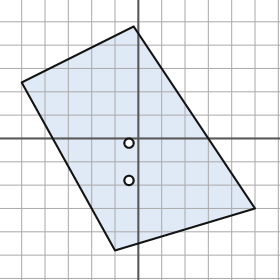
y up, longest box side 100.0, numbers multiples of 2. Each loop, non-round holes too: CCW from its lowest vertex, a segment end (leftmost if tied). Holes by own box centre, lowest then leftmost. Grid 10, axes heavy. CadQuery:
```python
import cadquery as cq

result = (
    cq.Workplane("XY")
    .moveTo(-10.0, -48.0)
    .lineTo(50.0, -30.0)
    .lineTo(-2.0, 48.0)
    .lineTo(-50.0, 24.0)
    .close()
    .moveTo(-4.0, -18.0)
    .circle(2.0)
    .moveTo(-4.0, -2.0)
    .circle(2.0)
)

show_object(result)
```